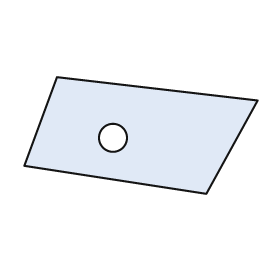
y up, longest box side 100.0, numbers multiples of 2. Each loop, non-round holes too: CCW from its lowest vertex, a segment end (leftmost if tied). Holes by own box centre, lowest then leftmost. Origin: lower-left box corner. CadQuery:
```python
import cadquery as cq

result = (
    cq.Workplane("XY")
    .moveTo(78.0, 0.0)
    .lineTo(100.0, 40.0)
    .lineTo(14.0, 50.0)
    .lineTo(0.0, 12.0)
    .close()
    .moveTo(38.0, 24.0)
    .circle(6.0)
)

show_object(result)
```